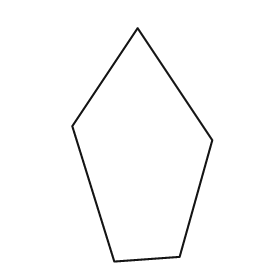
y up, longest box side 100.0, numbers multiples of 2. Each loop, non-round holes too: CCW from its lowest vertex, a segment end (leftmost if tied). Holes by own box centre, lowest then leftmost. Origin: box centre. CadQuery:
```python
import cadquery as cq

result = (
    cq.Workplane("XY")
    .moveTo(-12.0, -50.0)
    .lineTo(16.0, -48.0)
    .lineTo(30.0, 2.0)
    .lineTo(-2.0, 50.0)
    .lineTo(-30.0, 8.0)
    .close()
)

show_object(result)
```